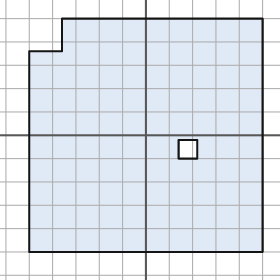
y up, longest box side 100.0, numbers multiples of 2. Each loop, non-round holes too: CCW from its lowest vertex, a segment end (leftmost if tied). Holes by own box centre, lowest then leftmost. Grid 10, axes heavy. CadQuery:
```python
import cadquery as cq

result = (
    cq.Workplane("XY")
    .moveTo(-50.0, -50.0)
    .lineTo(50.0, -50.0)
    .lineTo(50.0, 50.0)
    .lineTo(-36.0, 50.0)
    .lineTo(-36.0, 36.0)
    .lineTo(-50.0, 36.0)
    .close()
    .moveTo(14.0, -10.0)
    .lineTo(22.0, -10.0)
    .lineTo(22.0, -2.0)
    .lineTo(14.0, -2.0)
    .close()
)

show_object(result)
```